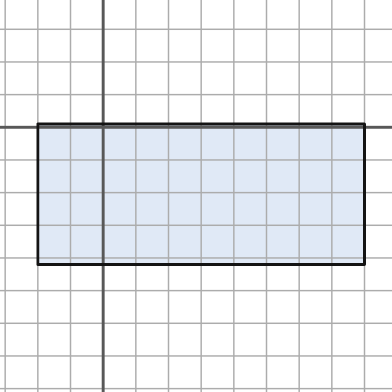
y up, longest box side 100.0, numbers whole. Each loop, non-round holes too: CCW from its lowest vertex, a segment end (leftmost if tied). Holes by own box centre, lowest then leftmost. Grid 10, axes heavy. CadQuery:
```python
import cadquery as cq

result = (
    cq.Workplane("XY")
    .moveTo(-20.0, -42.0)
    .lineTo(80.0, -42.0)
    .lineTo(80.0, 1.0)
    .lineTo(-20.0, 1.0)
    .close()
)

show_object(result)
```